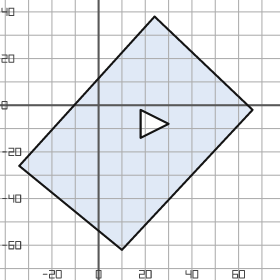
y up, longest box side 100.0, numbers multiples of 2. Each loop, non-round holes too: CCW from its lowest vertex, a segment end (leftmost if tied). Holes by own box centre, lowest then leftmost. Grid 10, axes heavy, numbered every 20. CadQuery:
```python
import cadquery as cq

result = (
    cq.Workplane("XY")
    .moveTo(10.0, -62.0)
    .lineTo(66.0, -2.0)
    .lineTo(24.0, 38.0)
    .lineTo(-34.0, -26.0)
    .close()
    .moveTo(18.0, -14.0)
    .lineTo(30.0, -8.0)
    .lineTo(18.0, -2.0)
    .close()
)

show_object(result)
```